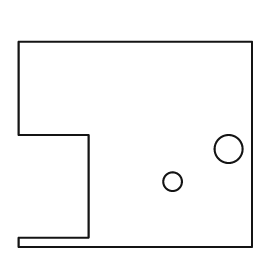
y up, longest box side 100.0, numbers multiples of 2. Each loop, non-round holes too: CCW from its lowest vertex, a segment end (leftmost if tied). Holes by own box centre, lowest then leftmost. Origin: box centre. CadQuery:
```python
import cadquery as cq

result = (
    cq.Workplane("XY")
    .moveTo(-50.0, -44.0)
    .lineTo(50.0, -44.0)
    .lineTo(50.0, 44.0)
    .lineTo(-50.0, 44.0)
    .lineTo(-50.0, 4.0)
    .lineTo(-20.0, 4.0)
    .lineTo(-20.0, -40.0)
    .lineTo(-50.0, -40.0)
    .close()
    .moveTo(16.0, -16.0)
    .circle(4.0)
    .moveTo(40.0, -2.0)
    .circle(6.0)
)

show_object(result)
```